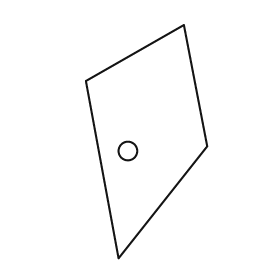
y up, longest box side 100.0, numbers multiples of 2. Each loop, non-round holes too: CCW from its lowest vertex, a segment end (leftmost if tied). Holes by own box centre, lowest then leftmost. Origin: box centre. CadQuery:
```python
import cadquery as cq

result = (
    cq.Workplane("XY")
    .moveTo(-12.0, -50.0)
    .lineTo(26.0, -2.0)
    .lineTo(16.0, 50.0)
    .lineTo(-26.0, 26.0)
    .close()
    .moveTo(-8.0, -4.0)
    .circle(4.0)
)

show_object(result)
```